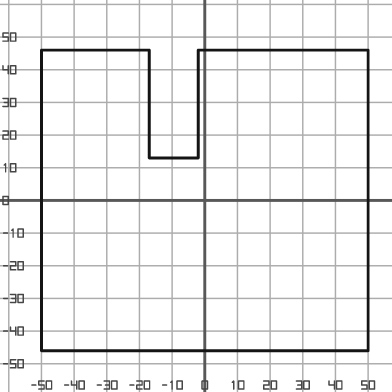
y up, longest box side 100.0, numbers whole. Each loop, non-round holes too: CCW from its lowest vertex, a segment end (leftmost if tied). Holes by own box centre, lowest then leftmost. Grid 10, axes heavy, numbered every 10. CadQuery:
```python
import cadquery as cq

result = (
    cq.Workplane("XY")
    .moveTo(-50.0, -46.0)
    .lineTo(50.0, -46.0)
    .lineTo(50.0, 46.0)
    .lineTo(-2.0, 46.0)
    .lineTo(-2.0, 13.0)
    .lineTo(-17.0, 13.0)
    .lineTo(-17.0, 46.0)
    .lineTo(-50.0, 46.0)
    .close()
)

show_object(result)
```